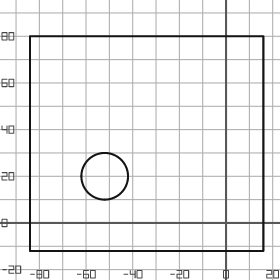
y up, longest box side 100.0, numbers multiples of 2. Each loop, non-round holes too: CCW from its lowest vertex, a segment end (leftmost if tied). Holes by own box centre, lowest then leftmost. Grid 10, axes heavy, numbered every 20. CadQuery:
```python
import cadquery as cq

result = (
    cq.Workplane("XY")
    .moveTo(-84.0, -12.0)
    .lineTo(16.0, -12.0)
    .lineTo(16.0, 80.0)
    .lineTo(-84.0, 80.0)
    .close()
    .moveTo(-52.0, 20.0)
    .circle(10.0)
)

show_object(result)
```